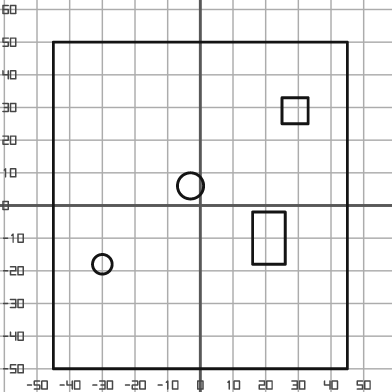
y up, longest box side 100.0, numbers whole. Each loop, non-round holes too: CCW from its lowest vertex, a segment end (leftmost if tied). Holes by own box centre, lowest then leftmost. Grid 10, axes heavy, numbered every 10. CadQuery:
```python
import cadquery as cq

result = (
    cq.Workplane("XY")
    .moveTo(-45.0, -50.0)
    .lineTo(45.0, -50.0)
    .lineTo(45.0, 50.0)
    .lineTo(-45.0, 50.0)
    .close()
    .moveTo(-30.0, -18.0)
    .circle(3.0)
    .moveTo(16.0, -18.0)
    .lineTo(26.0, -18.0)
    .lineTo(26.0, -2.0)
    .lineTo(16.0, -2.0)
    .close()
    .moveTo(-3.0, 6.0)
    .circle(4.0)
    .moveTo(25.0, 25.0)
    .lineTo(33.0, 25.0)
    .lineTo(33.0, 33.0)
    .lineTo(25.0, 33.0)
    .close()
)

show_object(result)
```